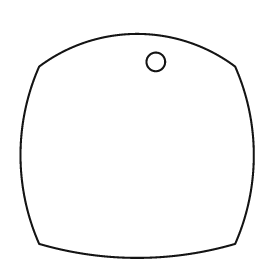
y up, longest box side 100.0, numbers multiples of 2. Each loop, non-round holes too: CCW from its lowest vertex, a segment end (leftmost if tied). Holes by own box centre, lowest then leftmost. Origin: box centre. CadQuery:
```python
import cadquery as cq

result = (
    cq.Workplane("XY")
    .moveTo(-42.0, -42.0)
    .threePointArc((0.0, -48.0), (42.0, -42.0))
    .threePointArc((50.0, -4.0), (42.0, 34.0))
    .threePointArc((0.0, 48.0), (-42.0, 34.0))
    .threePointArc((-50.0, -4.0), (-42.0, -42.0))
    .close()
    .moveTo(8.0, 36.0)
    .circle(4.0)
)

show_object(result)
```